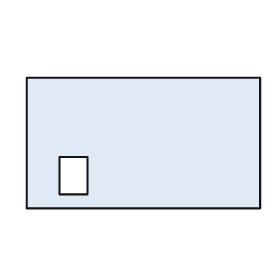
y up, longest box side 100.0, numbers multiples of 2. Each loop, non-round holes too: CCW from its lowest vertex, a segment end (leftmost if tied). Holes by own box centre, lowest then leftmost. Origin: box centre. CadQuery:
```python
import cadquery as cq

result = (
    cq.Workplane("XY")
    .moveTo(-50.0, -28.0)
    .lineTo(50.0, -28.0)
    .lineTo(50.0, 28.0)
    .lineTo(-50.0, 28.0)
    .close()
    .moveTo(-36.0, -22.0)
    .lineTo(-24.0, -22.0)
    .lineTo(-24.0, -6.0)
    .lineTo(-36.0, -6.0)
    .close()
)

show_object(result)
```